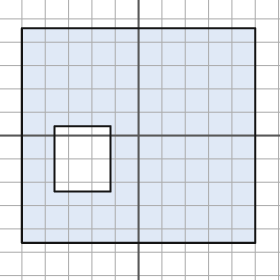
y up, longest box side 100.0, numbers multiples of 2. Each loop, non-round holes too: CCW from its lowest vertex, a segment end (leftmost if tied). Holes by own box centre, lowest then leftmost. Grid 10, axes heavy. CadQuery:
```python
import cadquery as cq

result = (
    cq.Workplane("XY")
    .moveTo(-50.0, -46.0)
    .lineTo(50.0, -46.0)
    .lineTo(50.0, 46.0)
    .lineTo(-50.0, 46.0)
    .close()
    .moveTo(-36.0, -24.0)
    .lineTo(-12.0, -24.0)
    .lineTo(-12.0, 4.0)
    .lineTo(-36.0, 4.0)
    .close()
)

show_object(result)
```